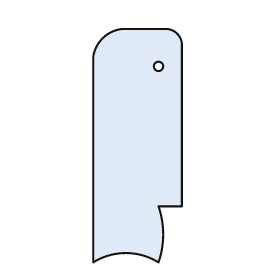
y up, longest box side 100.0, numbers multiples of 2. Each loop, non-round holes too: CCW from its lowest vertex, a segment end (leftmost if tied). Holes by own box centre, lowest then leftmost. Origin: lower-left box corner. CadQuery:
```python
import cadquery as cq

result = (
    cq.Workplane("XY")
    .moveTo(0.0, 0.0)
    .threePointArc((14.0, 4.0), (28.0, 0.0))
    .threePointArc((30.0, 12.0), (28.0, 24.0))
    .lineTo(38.0, 24.0)
    .lineTo(38.0, 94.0)
    .threePointArc((36.0, 98.0), (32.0, 100.0))
    .lineTo(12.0, 100.0)
    .threePointArc((4.0, 96.0), (0.0, 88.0))
    .close()
    .moveTo(28.0, 84.0)
    .circle(2.0)
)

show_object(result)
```